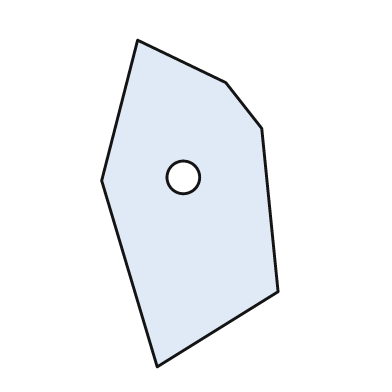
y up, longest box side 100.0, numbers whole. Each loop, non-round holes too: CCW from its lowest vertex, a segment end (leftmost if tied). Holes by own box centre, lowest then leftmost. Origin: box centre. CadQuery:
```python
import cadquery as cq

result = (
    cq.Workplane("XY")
    .moveTo(-10.0, -50.0)
    .lineTo(27.0, -27.0)
    .lineTo(22.0, 23.0)
    .lineTo(11.0, 37.0)
    .lineTo(-16.0, 50.0)
    .lineTo(-27.0, 7.0)
    .close()
    .moveTo(-2.0, 8.0)
    .circle(5.0)
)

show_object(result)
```